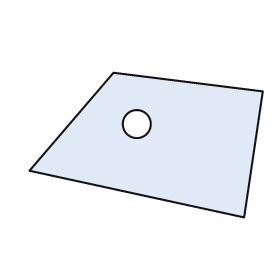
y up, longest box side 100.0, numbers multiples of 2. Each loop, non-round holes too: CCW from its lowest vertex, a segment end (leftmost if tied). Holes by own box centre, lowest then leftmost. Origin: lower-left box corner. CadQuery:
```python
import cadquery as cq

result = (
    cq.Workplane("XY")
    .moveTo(92.0, 0.0)
    .lineTo(100.0, 54.0)
    .lineTo(36.0, 62.0)
    .lineTo(0.0, 20.0)
    .close()
    .moveTo(46.0, 40.0)
    .circle(6.0)
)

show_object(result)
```